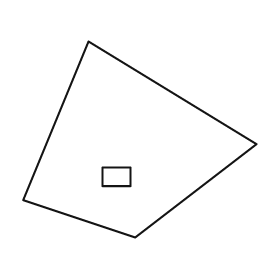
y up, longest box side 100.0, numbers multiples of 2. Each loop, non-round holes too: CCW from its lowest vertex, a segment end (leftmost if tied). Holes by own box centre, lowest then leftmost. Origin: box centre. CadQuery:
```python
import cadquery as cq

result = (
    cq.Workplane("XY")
    .moveTo(-2.0, -42.0)
    .lineTo(50.0, -2.0)
    .lineTo(-22.0, 42.0)
    .lineTo(-50.0, -26.0)
    .close()
    .moveTo(-16.0, -20.0)
    .lineTo(-4.0, -20.0)
    .lineTo(-4.0, -12.0)
    .lineTo(-16.0, -12.0)
    .close()
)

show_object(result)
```